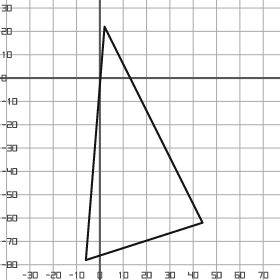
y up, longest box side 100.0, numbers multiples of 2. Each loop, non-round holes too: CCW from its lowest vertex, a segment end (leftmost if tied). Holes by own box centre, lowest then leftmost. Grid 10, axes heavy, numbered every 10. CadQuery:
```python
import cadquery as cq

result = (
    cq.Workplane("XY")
    .moveTo(-6.0, -78.0)
    .lineTo(44.0, -62.0)
    .lineTo(2.0, 22.0)
    .close()
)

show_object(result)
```